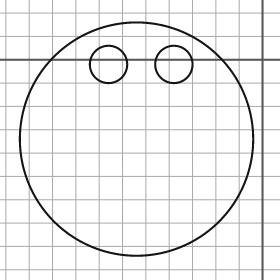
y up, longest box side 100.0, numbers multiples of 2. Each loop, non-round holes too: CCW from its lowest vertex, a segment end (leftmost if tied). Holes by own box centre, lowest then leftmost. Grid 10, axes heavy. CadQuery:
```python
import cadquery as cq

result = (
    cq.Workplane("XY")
    .moveTo(-54.0, -34.0)
    .circle(50.0)
    .moveTo(-66.0, -2.0)
    .circle(8.0)
    .moveTo(-38.0, -2.0)
    .circle(8.0)
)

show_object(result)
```